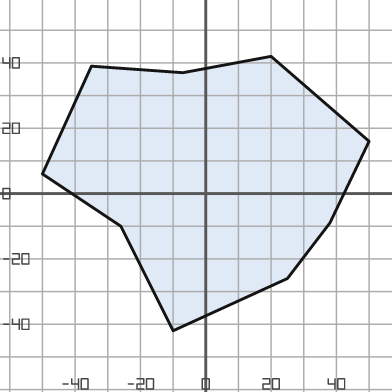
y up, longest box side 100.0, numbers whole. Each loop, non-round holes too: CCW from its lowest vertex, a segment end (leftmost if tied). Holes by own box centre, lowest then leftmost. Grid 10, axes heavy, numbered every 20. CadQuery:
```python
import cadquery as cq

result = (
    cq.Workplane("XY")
    .moveTo(-10.0, -42.0)
    .lineTo(25.0, -26.0)
    .lineTo(38.0, -9.0)
    .lineTo(50.0, 16.0)
    .lineTo(20.0, 42.0)
    .lineTo(-7.0, 37.0)
    .lineTo(-35.0, 39.0)
    .lineTo(-50.0, 6.0)
    .lineTo(-26.0, -10.0)
    .close()
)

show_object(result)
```